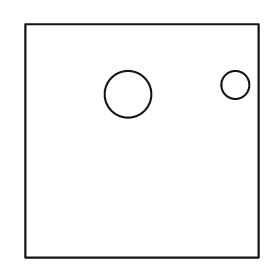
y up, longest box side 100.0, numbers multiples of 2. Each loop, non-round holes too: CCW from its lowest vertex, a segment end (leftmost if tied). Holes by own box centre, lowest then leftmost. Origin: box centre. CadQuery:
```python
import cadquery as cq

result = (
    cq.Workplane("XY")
    .moveTo(-50.0, -50.0)
    .lineTo(50.0, -50.0)
    .lineTo(50.0, 50.0)
    .lineTo(-50.0, 50.0)
    .close()
    .moveTo(-6.0, 20.0)
    .circle(10.0)
    .moveTo(40.0, 24.0)
    .circle(6.0)
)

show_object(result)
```